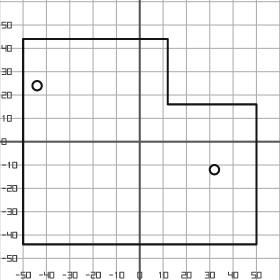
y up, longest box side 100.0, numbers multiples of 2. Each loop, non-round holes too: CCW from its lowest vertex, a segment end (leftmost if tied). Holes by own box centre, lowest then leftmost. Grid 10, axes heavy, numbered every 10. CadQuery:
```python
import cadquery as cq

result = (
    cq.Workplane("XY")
    .moveTo(-50.0, -44.0)
    .lineTo(50.0, -44.0)
    .lineTo(50.0, 16.0)
    .lineTo(12.0, 16.0)
    .lineTo(12.0, 44.0)
    .lineTo(-50.0, 44.0)
    .close()
    .moveTo(32.0, -12.0)
    .circle(2.0)
    .moveTo(-44.0, 24.0)
    .circle(2.0)
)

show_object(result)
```